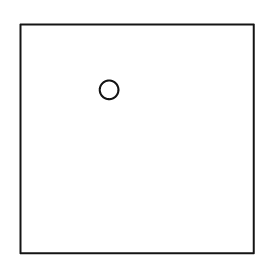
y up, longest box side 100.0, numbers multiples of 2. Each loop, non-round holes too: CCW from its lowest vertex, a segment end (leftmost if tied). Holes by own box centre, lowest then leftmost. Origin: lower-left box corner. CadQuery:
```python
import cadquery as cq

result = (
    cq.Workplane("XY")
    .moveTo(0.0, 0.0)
    .lineTo(100.0, 0.0)
    .lineTo(100.0, 98.0)
    .lineTo(0.0, 98.0)
    .close()
    .moveTo(38.0, 70.0)
    .circle(4.0)
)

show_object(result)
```